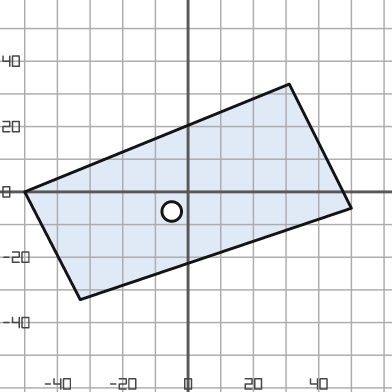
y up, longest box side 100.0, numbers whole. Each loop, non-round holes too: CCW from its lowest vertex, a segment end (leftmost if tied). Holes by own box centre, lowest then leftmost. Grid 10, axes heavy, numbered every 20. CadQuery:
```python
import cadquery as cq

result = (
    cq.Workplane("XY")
    .moveTo(-33.0, -33.0)
    .lineTo(50.0, -5.0)
    .lineTo(31.0, 33.0)
    .lineTo(-50.0, 0.0)
    .close()
    .moveTo(-5.0, -6.0)
    .circle(3.0)
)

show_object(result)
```